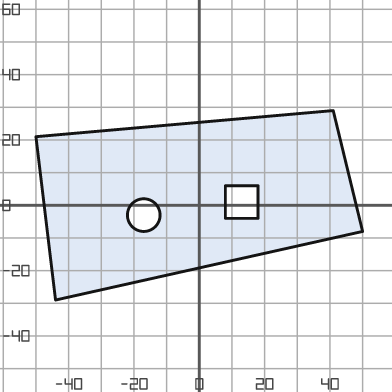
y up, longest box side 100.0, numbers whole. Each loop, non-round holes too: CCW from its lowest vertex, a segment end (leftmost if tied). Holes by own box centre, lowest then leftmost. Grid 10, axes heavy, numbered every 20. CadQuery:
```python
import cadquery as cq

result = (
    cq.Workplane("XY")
    .moveTo(-44.0, -29.0)
    .lineTo(50.0, -8.0)
    .lineTo(41.0, 29.0)
    .lineTo(-50.0, 21.0)
    .close()
    .moveTo(-17.0, -3.0)
    .circle(5.0)
    .moveTo(8.0, -4.0)
    .lineTo(18.0, -4.0)
    .lineTo(18.0, 6.0)
    .lineTo(8.0, 6.0)
    .close()
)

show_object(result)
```